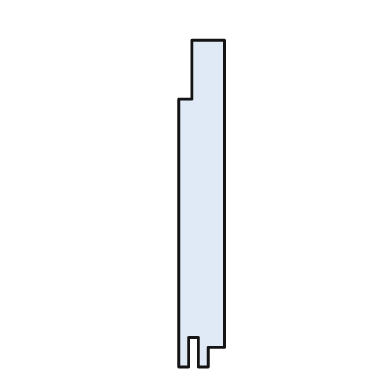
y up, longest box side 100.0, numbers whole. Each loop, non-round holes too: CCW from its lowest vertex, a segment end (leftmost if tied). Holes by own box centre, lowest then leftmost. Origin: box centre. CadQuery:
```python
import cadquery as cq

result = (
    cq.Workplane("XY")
    .moveTo(-7.0, -50.0)
    .lineTo(-4.0, -50.0)
    .lineTo(-4.0, -41.0)
    .lineTo(-1.0, -41.0)
    .lineTo(-1.0, -50.0)
    .lineTo(2.0, -50.0)
    .lineTo(2.0, -44.0)
    .lineTo(7.0, -44.0)
    .lineTo(7.0, 50.0)
    .lineTo(-3.0, 50.0)
    .lineTo(-3.0, 32.0)
    .lineTo(-7.0, 32.0)
    .close()
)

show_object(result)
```